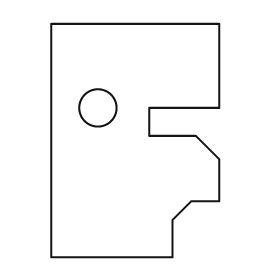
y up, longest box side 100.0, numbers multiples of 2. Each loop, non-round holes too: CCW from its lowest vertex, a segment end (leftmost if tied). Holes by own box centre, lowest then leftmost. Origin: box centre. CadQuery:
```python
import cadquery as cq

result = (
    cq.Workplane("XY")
    .moveTo(-36.0, -50.0)
    .lineTo(16.0, -50.0)
    .lineTo(16.0, -34.0)
    .lineTo(24.0, -26.0)
    .lineTo(36.0, -26.0)
    .lineTo(36.0, -8.0)
    .lineTo(26.0, 2.0)
    .lineTo(6.0, 2.0)
    .lineTo(6.0, 14.0)
    .lineTo(36.0, 14.0)
    .lineTo(36.0, 50.0)
    .lineTo(-36.0, 50.0)
    .close()
    .moveTo(-16.0, 14.0)
    .circle(8.0)
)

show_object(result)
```